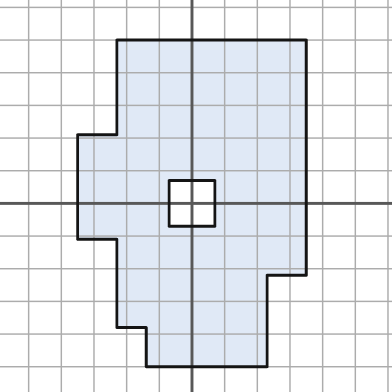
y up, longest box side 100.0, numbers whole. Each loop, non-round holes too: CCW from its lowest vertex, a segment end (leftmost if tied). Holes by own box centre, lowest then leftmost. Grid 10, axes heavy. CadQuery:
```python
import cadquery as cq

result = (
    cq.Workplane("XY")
    .moveTo(-14.0, -50.0)
    .lineTo(23.0, -50.0)
    .lineTo(23.0, -22.0)
    .lineTo(35.0, -22.0)
    .lineTo(35.0, 50.0)
    .lineTo(-23.0, 50.0)
    .lineTo(-23.0, 21.0)
    .lineTo(-35.0, 21.0)
    .lineTo(-35.0, -11.0)
    .lineTo(-23.0, -11.0)
    .lineTo(-23.0, -38.0)
    .lineTo(-14.0, -38.0)
    .close()
    .moveTo(-7.0, -7.0)
    .lineTo(7.0, -7.0)
    .lineTo(7.0, 7.0)
    .lineTo(-7.0, 7.0)
    .close()
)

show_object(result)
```